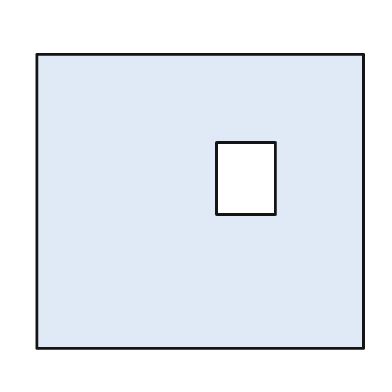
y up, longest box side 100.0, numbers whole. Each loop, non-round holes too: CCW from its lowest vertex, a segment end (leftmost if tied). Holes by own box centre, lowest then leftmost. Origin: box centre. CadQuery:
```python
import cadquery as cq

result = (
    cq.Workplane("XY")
    .moveTo(-50.0, -45.0)
    .lineTo(50.0, -45.0)
    .lineTo(50.0, 45.0)
    .lineTo(-50.0, 45.0)
    .close()
    .moveTo(5.0, -4.0)
    .lineTo(23.0, -4.0)
    .lineTo(23.0, 18.0)
    .lineTo(5.0, 18.0)
    .close()
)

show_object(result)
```